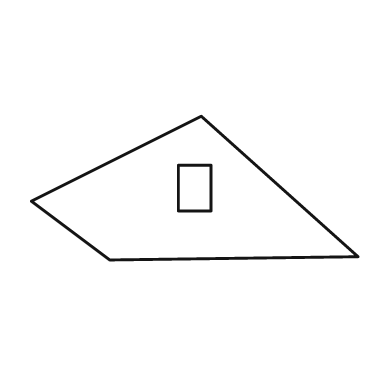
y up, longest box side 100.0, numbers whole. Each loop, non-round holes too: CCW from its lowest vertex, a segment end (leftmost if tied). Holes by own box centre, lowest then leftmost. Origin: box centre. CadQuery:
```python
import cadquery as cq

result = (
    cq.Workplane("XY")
    .moveTo(-26.0, -22.0)
    .lineTo(50.0, -21.0)
    .lineTo(2.0, 22.0)
    .lineTo(-50.0, -4.0)
    .close()
    .moveTo(-5.0, -7.0)
    .lineTo(5.0, -7.0)
    .lineTo(5.0, 7.0)
    .lineTo(-5.0, 7.0)
    .close()
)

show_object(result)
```